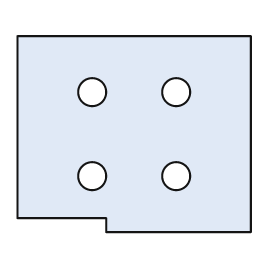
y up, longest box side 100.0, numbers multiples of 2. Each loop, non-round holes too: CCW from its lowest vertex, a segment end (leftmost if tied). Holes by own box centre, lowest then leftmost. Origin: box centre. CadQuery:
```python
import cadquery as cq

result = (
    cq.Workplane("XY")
    .moveTo(-12.0, -42.0)
    .lineTo(50.0, -42.0)
    .lineTo(50.0, 42.0)
    .lineTo(-50.0, 42.0)
    .lineTo(-50.0, -36.0)
    .lineTo(-12.0, -36.0)
    .close()
    .moveTo(-18.0, -18.0)
    .circle(6.0)
    .moveTo(18.0, -18.0)
    .circle(6.0)
    .moveTo(-18.0, 18.0)
    .circle(6.0)
    .moveTo(18.0, 18.0)
    .circle(6.0)
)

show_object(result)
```